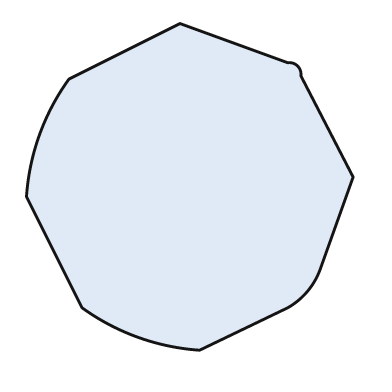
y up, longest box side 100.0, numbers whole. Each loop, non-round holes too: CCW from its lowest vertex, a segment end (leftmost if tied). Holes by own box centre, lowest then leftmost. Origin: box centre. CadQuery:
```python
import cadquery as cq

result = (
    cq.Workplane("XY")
    .moveTo(3.0, -50.0)
    .lineTo(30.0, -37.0)
    .threePointArc((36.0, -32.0), (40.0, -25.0))
    .lineTo(50.0, 3.0)
    .lineTo(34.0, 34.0)
    .threePointArc((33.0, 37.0), (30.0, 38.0))
    .lineTo(-3.0, 50.0)
    .lineTo(-37.0, 33.0)
    .threePointArc((-46.0, 16.0), (-50.0, -3.0))
    .lineTo(-33.0, -37.0)
    .threePointArc((-16.0, -46.0), (3.0, -50.0))
    .close()
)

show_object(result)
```